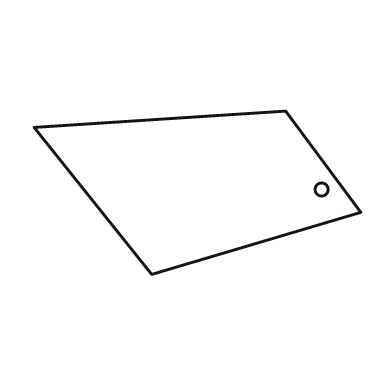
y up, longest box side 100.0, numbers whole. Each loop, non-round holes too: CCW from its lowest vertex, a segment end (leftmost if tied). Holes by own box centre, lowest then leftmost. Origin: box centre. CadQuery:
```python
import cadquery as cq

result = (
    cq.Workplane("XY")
    .moveTo(-14.0, -25.0)
    .lineTo(50.0, -6.0)
    .lineTo(27.0, 25.0)
    .lineTo(-50.0, 20.0)
    .close()
    .moveTo(38.0, 1.0)
    .circle(2.0)
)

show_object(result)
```